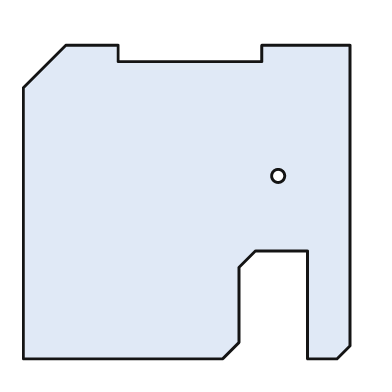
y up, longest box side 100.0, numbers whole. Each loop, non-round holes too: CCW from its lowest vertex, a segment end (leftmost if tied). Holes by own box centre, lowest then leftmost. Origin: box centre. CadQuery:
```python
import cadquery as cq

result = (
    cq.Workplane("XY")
    .moveTo(-50.0, -48.0)
    .lineTo(11.0, -48.0)
    .lineTo(16.0, -43.0)
    .lineTo(16.0, -20.0)
    .lineTo(21.0, -15.0)
    .lineTo(37.0, -15.0)
    .lineTo(37.0, -48.0)
    .lineTo(46.0, -48.0)
    .lineTo(50.0, -44.0)
    .lineTo(50.0, 48.0)
    .lineTo(23.0, 48.0)
    .lineTo(23.0, 43.0)
    .lineTo(-21.0, 43.0)
    .lineTo(-21.0, 48.0)
    .lineTo(-37.0, 48.0)
    .lineTo(-50.0, 35.0)
    .close()
    .moveTo(28.0, 8.0)
    .circle(2.0)
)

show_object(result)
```